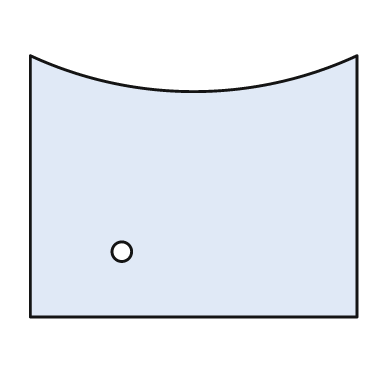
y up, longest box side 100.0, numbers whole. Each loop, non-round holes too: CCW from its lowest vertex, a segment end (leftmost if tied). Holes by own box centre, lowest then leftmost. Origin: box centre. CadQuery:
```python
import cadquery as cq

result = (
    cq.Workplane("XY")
    .moveTo(-50.0, -40.0)
    .lineTo(50.0, -40.0)
    .lineTo(50.0, 40.0)
    .threePointArc((0.0, 29.0), (-50.0, 40.0))
    .close()
    .moveTo(-22.0, -20.0)
    .circle(3.0)
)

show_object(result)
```